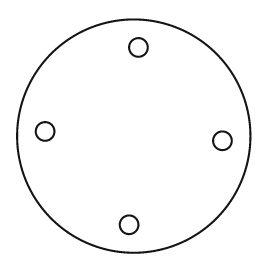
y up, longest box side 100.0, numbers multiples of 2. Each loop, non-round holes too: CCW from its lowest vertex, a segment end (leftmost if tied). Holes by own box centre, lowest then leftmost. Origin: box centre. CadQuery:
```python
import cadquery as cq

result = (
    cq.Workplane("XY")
    .moveTo(0.0, 0.0)
    .circle(50.0)
    .moveTo(-2.0, -38.0)
    .circle(4.0)
    .moveTo(38.0, -2.0)
    .circle(4.0)
    .moveTo(-38.0, 2.0)
    .circle(4.0)
    .moveTo(2.0, 38.0)
    .circle(4.0)
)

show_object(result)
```